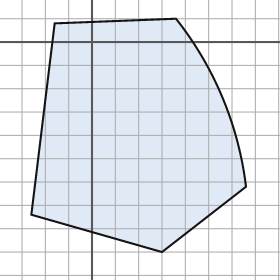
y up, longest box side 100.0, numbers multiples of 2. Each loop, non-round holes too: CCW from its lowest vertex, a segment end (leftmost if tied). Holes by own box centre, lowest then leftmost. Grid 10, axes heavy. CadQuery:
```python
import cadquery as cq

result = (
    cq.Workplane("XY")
    .moveTo(30.0, -90.0)
    .lineTo(66.0, -62.0)
    .threePointArc((56.0, -24.0), (36.0, 10.0))
    .lineTo(-16.0, 8.0)
    .lineTo(-26.0, -74.0)
    .close()
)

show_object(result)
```